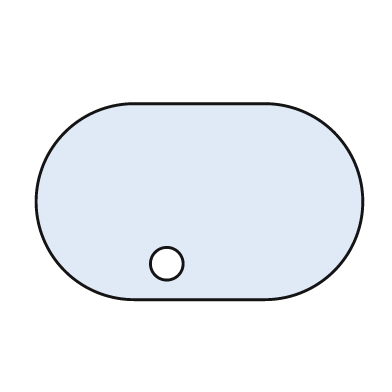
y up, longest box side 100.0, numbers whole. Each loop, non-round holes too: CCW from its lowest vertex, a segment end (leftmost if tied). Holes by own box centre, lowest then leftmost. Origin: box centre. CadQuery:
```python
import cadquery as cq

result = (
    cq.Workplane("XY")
    .moveTo(-20.0, -30.0)
    .lineTo(20.0, -30.0)
    .threePointArc((50.0, 0.0), (20.0, 30.0))
    .lineTo(-20.0, 30.0)
    .threePointArc((-50.0, 0.0), (-20.0, -30.0))
    .close()
    .moveTo(-10.0, -19.0)
    .circle(5.0)
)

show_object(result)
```